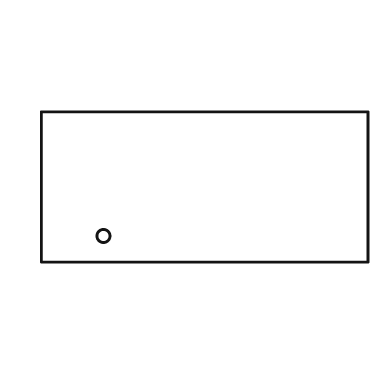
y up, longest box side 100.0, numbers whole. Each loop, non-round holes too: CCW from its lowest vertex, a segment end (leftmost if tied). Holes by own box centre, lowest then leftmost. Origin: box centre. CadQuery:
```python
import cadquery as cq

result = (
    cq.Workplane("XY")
    .moveTo(-50.0, -23.0)
    .lineTo(50.0, -23.0)
    .lineTo(50.0, 23.0)
    .lineTo(-50.0, 23.0)
    .close()
    .moveTo(-31.0, -15.0)
    .circle(2.0)
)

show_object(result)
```